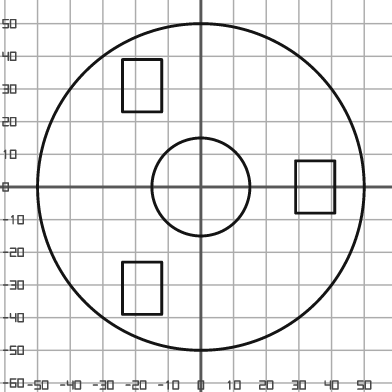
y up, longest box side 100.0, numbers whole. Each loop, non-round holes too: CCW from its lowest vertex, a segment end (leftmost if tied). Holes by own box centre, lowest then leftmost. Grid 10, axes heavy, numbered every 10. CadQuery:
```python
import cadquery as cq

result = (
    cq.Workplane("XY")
    .moveTo(0.0, 0.0)
    .circle(50.0)
    .moveTo(-24.0, -39.0)
    .lineTo(-12.0, -39.0)
    .lineTo(-12.0, -23.0)
    .lineTo(-24.0, -23.0)
    .close()
    .moveTo(0.0, 0.0)
    .circle(15.0)
    .moveTo(29.0, -8.0)
    .lineTo(41.0, -8.0)
    .lineTo(41.0, 8.0)
    .lineTo(29.0, 8.0)
    .close()
    .moveTo(-24.0, 23.0)
    .lineTo(-12.0, 23.0)
    .lineTo(-12.0, 39.0)
    .lineTo(-24.0, 39.0)
    .close()
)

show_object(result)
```